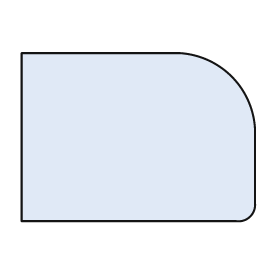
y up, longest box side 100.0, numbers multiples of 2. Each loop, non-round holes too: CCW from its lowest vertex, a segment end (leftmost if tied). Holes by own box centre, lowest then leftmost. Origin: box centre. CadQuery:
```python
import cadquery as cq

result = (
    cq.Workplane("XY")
    .moveTo(-50.0, -36.0)
    .lineTo(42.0, -36.0)
    .threePointArc((48.0, -34.0), (50.0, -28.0))
    .lineTo(50.0, 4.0)
    .threePointArc((40.0, 26.0), (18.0, 36.0))
    .lineTo(-50.0, 36.0)
    .close()
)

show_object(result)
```